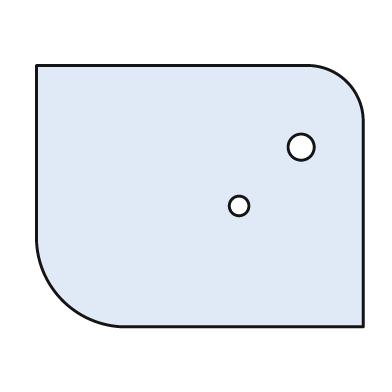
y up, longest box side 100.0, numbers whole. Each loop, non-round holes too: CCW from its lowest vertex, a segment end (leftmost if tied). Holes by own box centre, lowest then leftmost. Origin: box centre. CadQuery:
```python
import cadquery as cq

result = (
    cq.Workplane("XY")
    .moveTo(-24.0, -40.0)
    .lineTo(50.0, -40.0)
    .lineTo(50.0, 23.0)
    .threePointArc((45.0, 35.0), (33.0, 40.0))
    .lineTo(-50.0, 40.0)
    .lineTo(-50.0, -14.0)
    .threePointArc((-42.0, -32.0), (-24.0, -40.0))
    .close()
    .moveTo(12.0, -3.0)
    .circle(3.0)
    .moveTo(31.0, 15.0)
    .circle(4.0)
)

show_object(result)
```